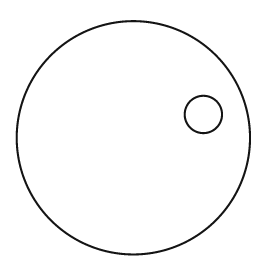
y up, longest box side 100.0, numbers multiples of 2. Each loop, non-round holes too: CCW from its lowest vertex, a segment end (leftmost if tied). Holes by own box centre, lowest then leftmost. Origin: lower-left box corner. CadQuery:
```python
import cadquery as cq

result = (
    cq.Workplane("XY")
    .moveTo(50.0, 50.0)
    .circle(50.0)
    .moveTo(80.0, 60.0)
    .circle(8.0)
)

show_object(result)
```